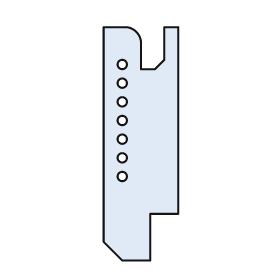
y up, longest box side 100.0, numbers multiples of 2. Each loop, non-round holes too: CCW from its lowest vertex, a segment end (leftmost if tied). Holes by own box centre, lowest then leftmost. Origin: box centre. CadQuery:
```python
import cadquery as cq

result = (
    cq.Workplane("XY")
    .moveTo(-8.0, -50.0)
    .lineTo(4.0, -50.0)
    .lineTo(4.0, -30.0)
    .lineTo(16.0, -30.0)
    .lineTo(16.0, 50.0)
    .lineTo(10.0, 50.0)
    .lineTo(10.0, 36.0)
    .lineTo(6.0, 32.0)
    .lineTo(0.0, 32.0)
    .lineTo(0.0, 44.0)
    .threePointArc((-2.0, 48.0), (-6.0, 50.0))
    .lineTo(-16.0, 50.0)
    .lineTo(-16.0, -42.0)
    .close()
    .moveTo(-8.0, -14.0)
    .circle(2.0)
    .moveTo(-8.0, -6.0)
    .circle(2.0)
    .moveTo(-8.0, 2.0)
    .circle(2.0)
    .moveTo(-8.0, 10.0)
    .circle(2.0)
    .moveTo(-8.0, 18.0)
    .circle(2.0)
    .moveTo(-8.0, 26.0)
    .circle(2.0)
    .moveTo(-8.0, 34.0)
    .circle(2.0)
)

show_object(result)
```